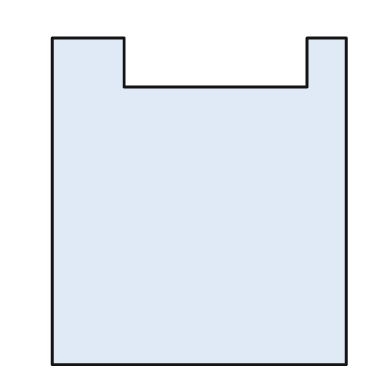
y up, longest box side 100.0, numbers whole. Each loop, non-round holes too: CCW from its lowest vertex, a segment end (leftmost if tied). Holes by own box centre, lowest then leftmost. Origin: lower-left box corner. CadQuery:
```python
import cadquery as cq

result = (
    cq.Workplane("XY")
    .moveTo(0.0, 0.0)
    .lineTo(90.0, 0.0)
    .lineTo(90.0, 100.0)
    .lineTo(78.0, 100.0)
    .lineTo(78.0, 85.0)
    .lineTo(22.0, 85.0)
    .lineTo(22.0, 100.0)
    .lineTo(0.0, 100.0)
    .close()
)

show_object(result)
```